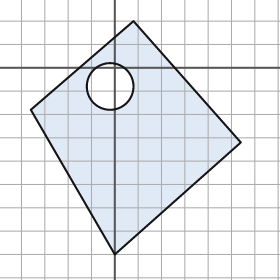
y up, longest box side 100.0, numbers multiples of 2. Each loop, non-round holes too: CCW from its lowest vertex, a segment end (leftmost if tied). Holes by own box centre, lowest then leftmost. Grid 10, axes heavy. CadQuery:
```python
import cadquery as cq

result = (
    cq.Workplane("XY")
    .moveTo(0.0, -80.0)
    .lineTo(54.0, -32.0)
    .lineTo(8.0, 20.0)
    .lineTo(-36.0, -18.0)
    .close()
    .moveTo(-2.0, -8.0)
    .circle(10.0)
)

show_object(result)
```